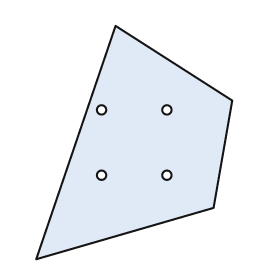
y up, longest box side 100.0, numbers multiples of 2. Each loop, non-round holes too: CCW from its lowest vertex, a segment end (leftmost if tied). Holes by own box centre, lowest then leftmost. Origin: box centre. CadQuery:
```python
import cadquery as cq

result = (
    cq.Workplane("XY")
    .moveTo(-42.0, -50.0)
    .lineTo(34.0, -28.0)
    .lineTo(42.0, 18.0)
    .lineTo(-8.0, 50.0)
    .close()
    .moveTo(-14.0, -14.0)
    .circle(2.0)
    .moveTo(14.0, -14.0)
    .circle(2.0)
    .moveTo(-14.0, 14.0)
    .circle(2.0)
    .moveTo(14.0, 14.0)
    .circle(2.0)
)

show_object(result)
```